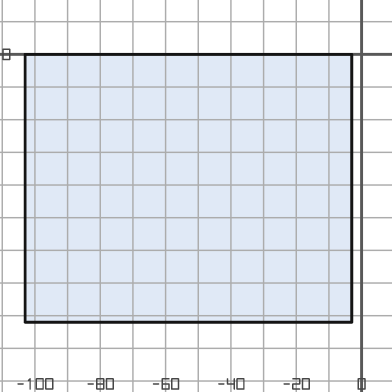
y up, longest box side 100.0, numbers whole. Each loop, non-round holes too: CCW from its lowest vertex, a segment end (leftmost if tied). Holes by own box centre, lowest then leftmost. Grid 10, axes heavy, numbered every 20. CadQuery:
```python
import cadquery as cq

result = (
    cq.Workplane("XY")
    .moveTo(-103.0, -82.0)
    .lineTo(-3.0, -82.0)
    .lineTo(-3.0, 0.0)
    .lineTo(-103.0, 0.0)
    .close()
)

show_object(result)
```